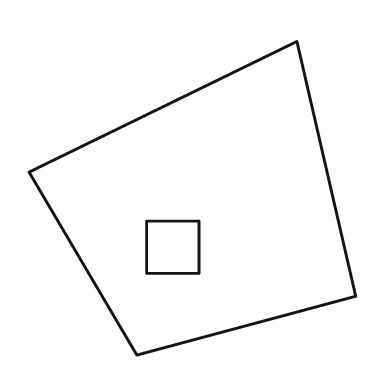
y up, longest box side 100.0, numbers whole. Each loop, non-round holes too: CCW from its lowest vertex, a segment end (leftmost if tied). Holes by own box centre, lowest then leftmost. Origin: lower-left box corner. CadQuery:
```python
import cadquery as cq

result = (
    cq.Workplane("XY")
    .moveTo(33.0, 0.0)
    .lineTo(100.0, 18.0)
    .lineTo(82.0, 96.0)
    .lineTo(0.0, 56.0)
    .close()
    .moveTo(36.0, 25.0)
    .lineTo(52.0, 25.0)
    .lineTo(52.0, 41.0)
    .lineTo(36.0, 41.0)
    .close()
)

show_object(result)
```